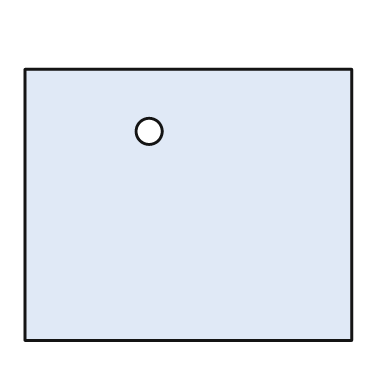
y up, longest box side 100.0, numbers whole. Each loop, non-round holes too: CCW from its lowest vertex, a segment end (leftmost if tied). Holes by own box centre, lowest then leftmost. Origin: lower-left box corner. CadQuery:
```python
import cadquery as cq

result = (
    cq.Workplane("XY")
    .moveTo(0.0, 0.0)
    .lineTo(100.0, 0.0)
    .lineTo(100.0, 83.0)
    .lineTo(0.0, 83.0)
    .close()
    .moveTo(38.0, 64.0)
    .circle(4.0)
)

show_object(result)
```